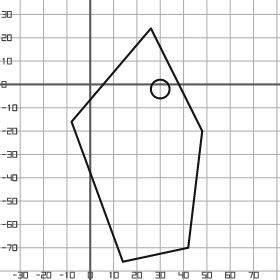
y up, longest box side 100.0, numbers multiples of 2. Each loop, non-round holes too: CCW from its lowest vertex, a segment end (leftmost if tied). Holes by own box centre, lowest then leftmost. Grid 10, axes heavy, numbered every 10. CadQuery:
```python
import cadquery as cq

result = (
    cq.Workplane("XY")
    .moveTo(14.0, -76.0)
    .lineTo(42.0, -70.0)
    .lineTo(48.0, -20.0)
    .lineTo(26.0, 24.0)
    .lineTo(-8.0, -16.0)
    .close()
    .moveTo(30.0, -2.0)
    .circle(4.0)
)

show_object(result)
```